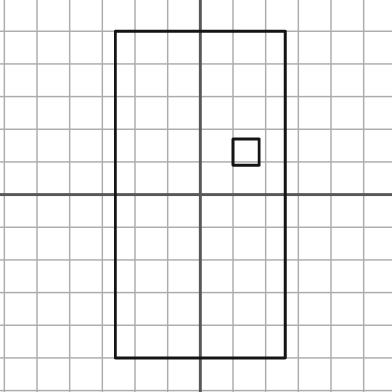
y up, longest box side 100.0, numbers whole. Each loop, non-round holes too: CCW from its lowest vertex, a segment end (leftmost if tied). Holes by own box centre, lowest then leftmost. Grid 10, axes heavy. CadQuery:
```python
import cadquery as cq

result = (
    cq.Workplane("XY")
    .moveTo(-26.0, -50.0)
    .lineTo(26.0, -50.0)
    .lineTo(26.0, 50.0)
    .lineTo(-26.0, 50.0)
    .close()
    .moveTo(10.0, 9.0)
    .lineTo(18.0, 9.0)
    .lineTo(18.0, 17.0)
    .lineTo(10.0, 17.0)
    .close()
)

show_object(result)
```